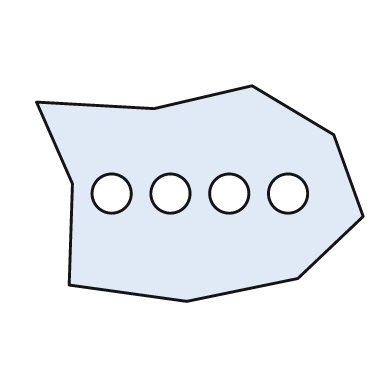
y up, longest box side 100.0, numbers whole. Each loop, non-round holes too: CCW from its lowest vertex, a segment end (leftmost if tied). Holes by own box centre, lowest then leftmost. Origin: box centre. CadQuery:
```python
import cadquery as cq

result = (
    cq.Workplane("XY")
    .moveTo(-4.0, -33.0)
    .lineTo(30.0, -26.0)
    .lineTo(50.0, -7.0)
    .lineTo(41.0, 18.0)
    .lineTo(16.0, 33.0)
    .lineTo(-14.0, 26.0)
    .lineTo(-50.0, 28.0)
    .lineTo(-39.0, 3.0)
    .lineTo(-40.0, -28.0)
    .close()
    .moveTo(-27.0, 0.0)
    .circle(6.0)
    .moveTo(-9.0, 0.0)
    .circle(6.0)
    .moveTo(9.0, 0.0)
    .circle(6.0)
    .moveTo(27.0, 0.0)
    .circle(6.0)
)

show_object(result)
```